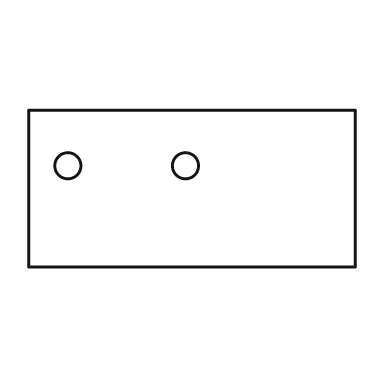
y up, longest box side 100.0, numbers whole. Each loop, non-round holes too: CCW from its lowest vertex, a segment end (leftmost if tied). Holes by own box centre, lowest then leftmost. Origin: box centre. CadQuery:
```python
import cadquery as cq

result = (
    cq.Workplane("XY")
    .moveTo(-50.0, -24.0)
    .lineTo(50.0, -24.0)
    .lineTo(50.0, 24.0)
    .lineTo(-50.0, 24.0)
    .close()
    .moveTo(-38.0, 7.0)
    .circle(4.0)
    .moveTo(-2.0, 7.0)
    .circle(4.0)
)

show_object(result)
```